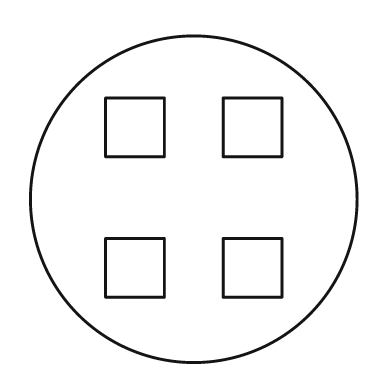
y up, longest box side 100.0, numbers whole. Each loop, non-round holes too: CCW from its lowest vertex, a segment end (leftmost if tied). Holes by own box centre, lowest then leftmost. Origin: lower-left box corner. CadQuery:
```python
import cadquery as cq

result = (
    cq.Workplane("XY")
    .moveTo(50.0, 50.0)
    .circle(50.0)
    .moveTo(23.0, 20.0)
    .lineTo(41.0, 20.0)
    .lineTo(41.0, 38.0)
    .lineTo(23.0, 38.0)
    .close()
    .moveTo(59.0, 20.0)
    .lineTo(77.0, 20.0)
    .lineTo(77.0, 38.0)
    .lineTo(59.0, 38.0)
    .close()
    .moveTo(23.0, 63.0)
    .lineTo(41.0, 63.0)
    .lineTo(41.0, 81.0)
    .lineTo(23.0, 81.0)
    .close()
    .moveTo(59.0, 63.0)
    .lineTo(77.0, 63.0)
    .lineTo(77.0, 81.0)
    .lineTo(59.0, 81.0)
    .close()
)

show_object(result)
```